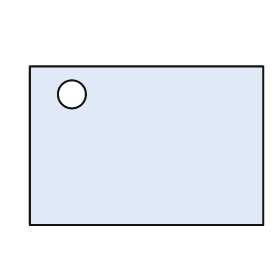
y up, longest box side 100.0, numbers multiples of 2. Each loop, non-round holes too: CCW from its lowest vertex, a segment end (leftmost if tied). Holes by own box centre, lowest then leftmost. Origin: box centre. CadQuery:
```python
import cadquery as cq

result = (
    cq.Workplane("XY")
    .moveTo(-50.0, -34.0)
    .lineTo(50.0, -34.0)
    .lineTo(50.0, 34.0)
    .lineTo(-50.0, 34.0)
    .close()
    .moveTo(-32.0, 22.0)
    .circle(6.0)
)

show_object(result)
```